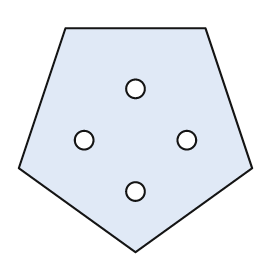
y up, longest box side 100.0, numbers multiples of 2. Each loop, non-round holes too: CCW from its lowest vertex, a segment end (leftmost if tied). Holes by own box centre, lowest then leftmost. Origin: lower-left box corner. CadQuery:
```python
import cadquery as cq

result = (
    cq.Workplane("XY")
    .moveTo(50.0, 0.0)
    .lineTo(100.0, 36.0)
    .lineTo(80.0, 96.0)
    .lineTo(20.0, 96.0)
    .lineTo(0.0, 36.0)
    .close()
    .moveTo(50.0, 26.0)
    .circle(4.0)
    .moveTo(28.0, 48.0)
    .circle(4.0)
    .moveTo(72.0, 48.0)
    .circle(4.0)
    .moveTo(50.0, 70.0)
    .circle(4.0)
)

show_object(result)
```